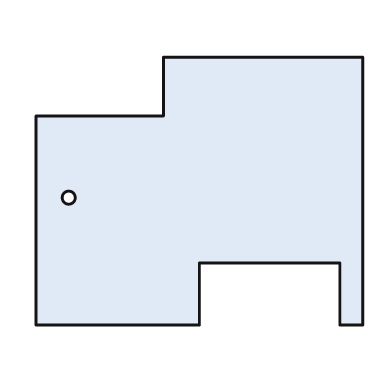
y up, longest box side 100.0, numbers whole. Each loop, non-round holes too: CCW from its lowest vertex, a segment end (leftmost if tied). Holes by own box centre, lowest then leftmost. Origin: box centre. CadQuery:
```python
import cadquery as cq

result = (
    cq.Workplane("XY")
    .moveTo(-50.0, -41.0)
    .lineTo(0.0, -41.0)
    .lineTo(0.0, -22.0)
    .lineTo(43.0, -22.0)
    .lineTo(43.0, -41.0)
    .lineTo(50.0, -41.0)
    .lineTo(50.0, 41.0)
    .lineTo(-11.0, 41.0)
    .lineTo(-11.0, 23.0)
    .lineTo(-50.0, 23.0)
    .close()
    .moveTo(-40.0, -2.0)
    .circle(2.0)
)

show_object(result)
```